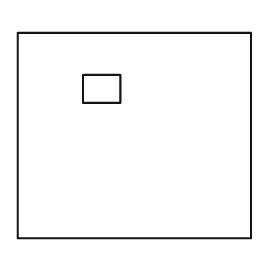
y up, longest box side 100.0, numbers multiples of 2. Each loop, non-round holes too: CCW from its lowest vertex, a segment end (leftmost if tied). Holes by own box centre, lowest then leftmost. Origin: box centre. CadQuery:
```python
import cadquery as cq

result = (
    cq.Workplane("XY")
    .moveTo(-50.0, -44.0)
    .lineTo(50.0, -44.0)
    .lineTo(50.0, 44.0)
    .lineTo(-50.0, 44.0)
    .close()
    .moveTo(-22.0, 14.0)
    .lineTo(-6.0, 14.0)
    .lineTo(-6.0, 26.0)
    .lineTo(-22.0, 26.0)
    .close()
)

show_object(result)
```